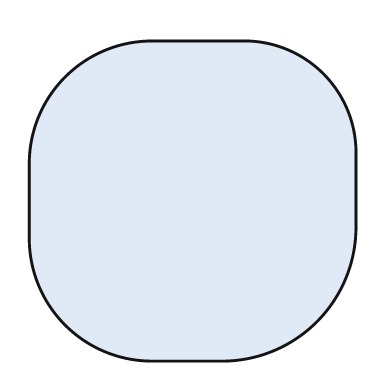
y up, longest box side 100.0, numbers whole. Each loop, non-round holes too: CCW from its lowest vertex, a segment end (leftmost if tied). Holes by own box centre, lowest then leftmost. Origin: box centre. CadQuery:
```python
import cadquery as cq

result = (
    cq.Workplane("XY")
    .moveTo(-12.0, -49.0)
    .lineTo(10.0, -49.0)
    .threePointArc((38.0, -37.0), (50.0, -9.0))
    .lineTo(50.0, 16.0)
    .threePointArc((40.0, 39.0), (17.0, 49.0))
    .lineTo(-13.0, 49.0)
    .threePointArc((-39.0, 38.0), (-50.0, 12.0))
    .lineTo(-50.0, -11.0)
    .threePointArc((-39.0, -38.0), (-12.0, -49.0))
    .close()
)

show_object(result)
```